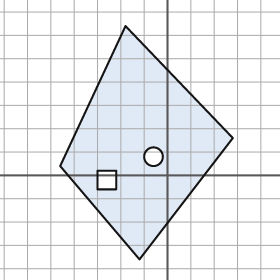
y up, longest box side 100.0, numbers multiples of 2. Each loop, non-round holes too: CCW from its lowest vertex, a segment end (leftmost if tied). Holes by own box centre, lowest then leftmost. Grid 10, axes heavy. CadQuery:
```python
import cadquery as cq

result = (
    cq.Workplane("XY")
    .moveTo(-12.0, -36.0)
    .lineTo(28.0, 16.0)
    .lineTo(-18.0, 64.0)
    .lineTo(-46.0, 4.0)
    .close()
    .moveTo(-30.0, -6.0)
    .lineTo(-22.0, -6.0)
    .lineTo(-22.0, 2.0)
    .lineTo(-30.0, 2.0)
    .close()
    .moveTo(-6.0, 8.0)
    .circle(4.0)
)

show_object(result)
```